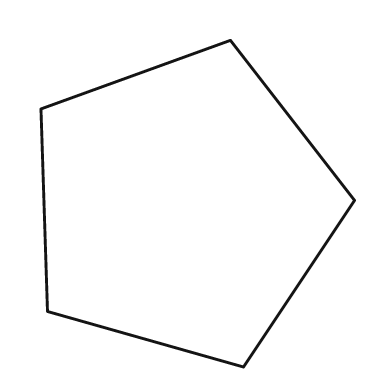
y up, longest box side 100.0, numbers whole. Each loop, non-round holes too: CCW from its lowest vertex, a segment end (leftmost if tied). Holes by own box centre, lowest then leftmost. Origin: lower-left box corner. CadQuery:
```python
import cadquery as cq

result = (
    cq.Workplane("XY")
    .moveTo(62.0, 0.0)
    .lineTo(96.0, 51.0)
    .lineTo(58.0, 100.0)
    .lineTo(0.0, 79.0)
    .lineTo(2.0, 17.0)
    .close()
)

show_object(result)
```